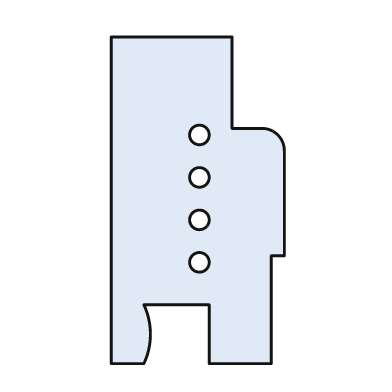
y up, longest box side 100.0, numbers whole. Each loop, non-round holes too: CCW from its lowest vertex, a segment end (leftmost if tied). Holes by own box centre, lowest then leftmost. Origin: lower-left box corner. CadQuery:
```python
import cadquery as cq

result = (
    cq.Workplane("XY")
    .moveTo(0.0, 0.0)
    .lineTo(10.0, 0.0)
    .threePointArc((12.0, 9.0), (10.0, 18.0))
    .lineTo(30.0, 18.0)
    .lineTo(30.0, 0.0)
    .lineTo(49.0, 0.0)
    .lineTo(49.0, 33.0)
    .lineTo(53.0, 33.0)
    .lineTo(53.0, 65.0)
    .threePointArc((51.0, 70.0), (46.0, 72.0))
    .lineTo(37.0, 72.0)
    .lineTo(37.0, 100.0)
    .lineTo(0.0, 100.0)
    .close()
    .moveTo(27.0, 31.0)
    .circle(3.0)
    .moveTo(27.0, 44.0)
    .circle(3.0)
    .moveTo(27.0, 57.0)
    .circle(3.0)
    .moveTo(27.0, 70.0)
    .circle(3.0)
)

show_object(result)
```